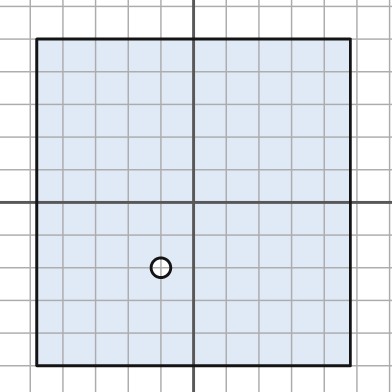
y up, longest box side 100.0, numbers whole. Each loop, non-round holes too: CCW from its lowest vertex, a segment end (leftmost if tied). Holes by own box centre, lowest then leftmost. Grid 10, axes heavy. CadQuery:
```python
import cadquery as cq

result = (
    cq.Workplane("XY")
    .moveTo(-48.0, -50.0)
    .lineTo(48.0, -50.0)
    .lineTo(48.0, 50.0)
    .lineTo(-48.0, 50.0)
    .close()
    .moveTo(-10.0, -20.0)
    .circle(3.0)
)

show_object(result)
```